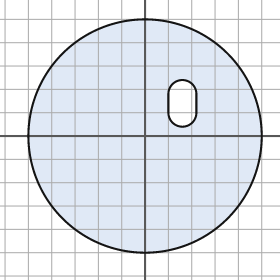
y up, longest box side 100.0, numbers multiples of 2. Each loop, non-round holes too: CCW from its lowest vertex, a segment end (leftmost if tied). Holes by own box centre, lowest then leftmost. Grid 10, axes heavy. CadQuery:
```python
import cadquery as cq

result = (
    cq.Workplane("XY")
    .moveTo(0.0, 0.0)
    .circle(50.0)
    .moveTo(10.0, 10.0)
    .threePointArc((16.0, 4.0), (22.0, 10.0))
    .lineTo(22.0, 18.0)
    .threePointArc((16.0, 24.0), (10.0, 18.0))
    .close()
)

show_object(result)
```